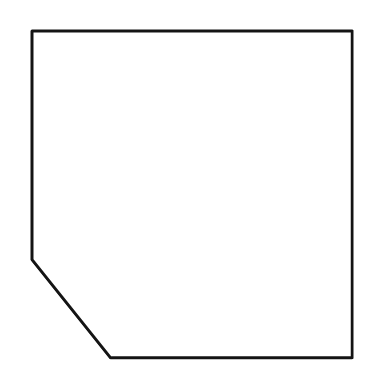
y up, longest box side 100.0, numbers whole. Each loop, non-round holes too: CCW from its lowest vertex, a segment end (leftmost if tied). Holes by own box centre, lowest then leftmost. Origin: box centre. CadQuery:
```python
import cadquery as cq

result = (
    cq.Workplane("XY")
    .moveTo(-25.0, -50.0)
    .lineTo(49.0, -50.0)
    .lineTo(49.0, 50.0)
    .lineTo(-49.0, 50.0)
    .lineTo(-49.0, -20.0)
    .close()
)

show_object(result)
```